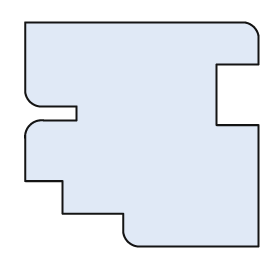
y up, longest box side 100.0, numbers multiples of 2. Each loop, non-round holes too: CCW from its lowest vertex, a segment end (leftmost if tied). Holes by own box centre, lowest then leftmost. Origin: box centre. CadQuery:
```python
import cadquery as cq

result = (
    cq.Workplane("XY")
    .moveTo(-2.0, -48.0)
    .lineTo(50.0, -48.0)
    .lineTo(50.0, 4.0)
    .lineTo(32.0, 4.0)
    .lineTo(32.0, 30.0)
    .lineTo(50.0, 30.0)
    .lineTo(50.0, 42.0)
    .threePointArc((48.0, 46.0), (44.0, 48.0))
    .lineTo(-50.0, 48.0)
    .lineTo(-50.0, 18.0)
    .threePointArc((-48.0, 14.0), (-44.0, 12.0))
    .lineTo(-28.0, 12.0)
    .lineTo(-28.0, 6.0)
    .lineTo(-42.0, 6.0)
    .threePointArc((-48.0, 4.0), (-50.0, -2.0))
    .lineTo(-50.0, -20.0)
    .lineTo(-34.0, -20.0)
    .lineTo(-34.0, -34.0)
    .lineTo(-8.0, -34.0)
    .lineTo(-8.0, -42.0)
    .threePointArc((-6.0, -46.0), (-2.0, -48.0))
    .close()
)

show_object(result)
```